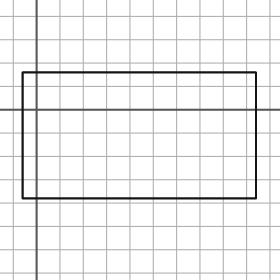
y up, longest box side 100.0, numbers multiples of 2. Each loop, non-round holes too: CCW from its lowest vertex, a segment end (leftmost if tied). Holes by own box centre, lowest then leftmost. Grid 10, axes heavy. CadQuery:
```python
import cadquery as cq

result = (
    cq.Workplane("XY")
    .moveTo(-6.0, -38.0)
    .lineTo(94.0, -38.0)
    .lineTo(94.0, 16.0)
    .lineTo(-6.0, 16.0)
    .close()
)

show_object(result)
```